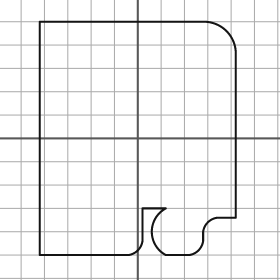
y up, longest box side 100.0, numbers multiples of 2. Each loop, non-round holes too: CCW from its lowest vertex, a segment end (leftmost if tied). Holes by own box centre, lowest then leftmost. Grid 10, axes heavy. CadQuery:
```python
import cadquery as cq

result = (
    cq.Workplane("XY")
    .moveTo(-42.0, -50.0)
    .lineTo(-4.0, -50.0)
    .threePointArc((0.0, -48.0), (2.0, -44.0))
    .lineTo(2.0, -30.0)
    .lineTo(12.0, -30.0)
    .threePointArc((6.0, -40.0), (12.0, -50.0))
    .lineTo(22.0, -50.0)
    .threePointArc((26.0, -48.0), (28.0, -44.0))
    .lineTo(28.0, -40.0)
    .threePointArc((30.0, -36.0), (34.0, -34.0))
    .lineTo(42.0, -34.0)
    .lineTo(42.0, 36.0)
    .threePointArc((38.0, 46.0), (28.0, 50.0))
    .lineTo(-42.0, 50.0)
    .close()
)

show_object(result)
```